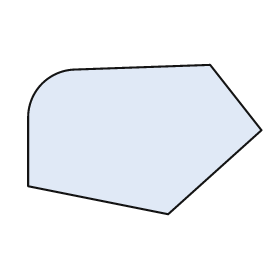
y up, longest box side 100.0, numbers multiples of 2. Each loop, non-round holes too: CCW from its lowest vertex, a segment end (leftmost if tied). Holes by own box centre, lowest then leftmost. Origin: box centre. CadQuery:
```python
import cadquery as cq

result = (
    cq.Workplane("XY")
    .moveTo(10.0, -32.0)
    .lineTo(50.0, 4.0)
    .lineTo(28.0, 32.0)
    .lineTo(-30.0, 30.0)
    .threePointArc((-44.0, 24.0), (-50.0, 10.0))
    .lineTo(-50.0, -20.0)
    .close()
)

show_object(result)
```